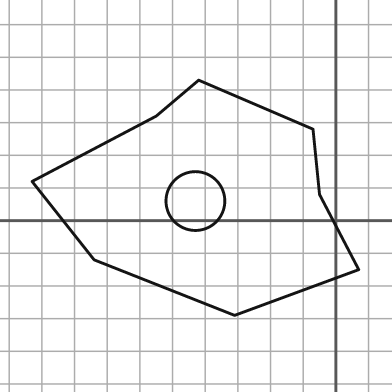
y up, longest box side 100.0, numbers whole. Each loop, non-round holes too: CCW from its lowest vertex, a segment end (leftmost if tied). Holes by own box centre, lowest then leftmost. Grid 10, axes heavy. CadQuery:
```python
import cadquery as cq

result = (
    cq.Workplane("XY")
    .moveTo(-31.0, -29.0)
    .lineTo(7.0, -15.0)
    .lineTo(-5.0, 8.0)
    .lineTo(-7.0, 28.0)
    .lineTo(-42.0, 43.0)
    .lineTo(-55.0, 32.0)
    .lineTo(-93.0, 12.0)
    .lineTo(-74.0, -12.0)
    .close()
    .moveTo(-43.0, 6.0)
    .circle(9.0)
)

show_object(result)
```